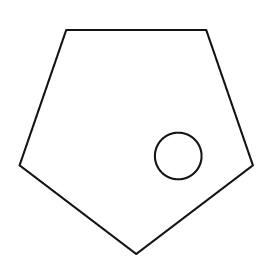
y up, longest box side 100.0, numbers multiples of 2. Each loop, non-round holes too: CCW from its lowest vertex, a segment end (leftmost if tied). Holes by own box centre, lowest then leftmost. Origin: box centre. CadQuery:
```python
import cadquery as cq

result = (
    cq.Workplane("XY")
    .moveTo(0.0, -48.0)
    .lineTo(50.0, -10.0)
    .lineTo(30.0, 48.0)
    .lineTo(-30.0, 48.0)
    .lineTo(-50.0, -10.0)
    .close()
    .moveTo(18.0, -6.0)
    .circle(10.0)
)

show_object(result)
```